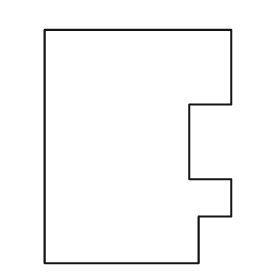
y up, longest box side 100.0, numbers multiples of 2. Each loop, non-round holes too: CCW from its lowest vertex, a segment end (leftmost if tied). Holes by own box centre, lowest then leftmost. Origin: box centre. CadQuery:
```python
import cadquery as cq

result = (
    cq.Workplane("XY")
    .moveTo(-40.0, -50.0)
    .lineTo(26.0, -50.0)
    .lineTo(26.0, -30.0)
    .lineTo(40.0, -30.0)
    .lineTo(40.0, -14.0)
    .lineTo(22.0, -14.0)
    .lineTo(22.0, 18.0)
    .lineTo(40.0, 18.0)
    .lineTo(40.0, 50.0)
    .lineTo(-40.0, 50.0)
    .close()
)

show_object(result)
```